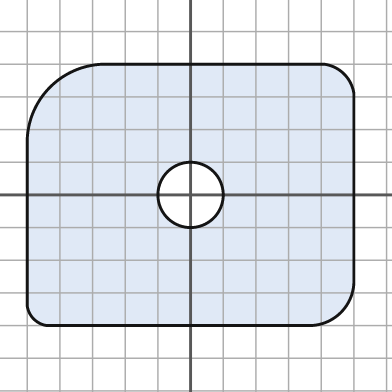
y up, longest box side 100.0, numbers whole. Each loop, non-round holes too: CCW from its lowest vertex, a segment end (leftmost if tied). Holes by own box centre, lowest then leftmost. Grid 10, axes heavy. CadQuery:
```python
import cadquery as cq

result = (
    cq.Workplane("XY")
    .moveTo(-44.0, -40.0)
    .lineTo(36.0, -40.0)
    .threePointArc((46.0, -36.0), (50.0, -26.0))
    .lineTo(50.0, 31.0)
    .threePointArc((47.0, 37.0), (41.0, 40.0))
    .lineTo(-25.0, 40.0)
    .threePointArc((-43.0, 33.0), (-50.0, 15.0))
    .lineTo(-50.0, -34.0)
    .threePointArc((-48.0, -38.0), (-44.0, -40.0))
    .close()
    .moveTo(0.0, 0.0)
    .circle(10.0)
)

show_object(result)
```